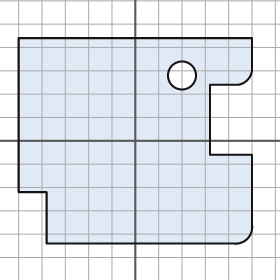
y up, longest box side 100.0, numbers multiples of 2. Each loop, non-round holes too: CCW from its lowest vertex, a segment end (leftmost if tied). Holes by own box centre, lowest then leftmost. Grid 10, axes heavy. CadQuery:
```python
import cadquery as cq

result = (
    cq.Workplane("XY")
    .moveTo(-38.0, -44.0)
    .lineTo(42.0, -44.0)
    .threePointArc((48.0, -42.0), (50.0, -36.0))
    .lineTo(50.0, -6.0)
    .lineTo(32.0, -6.0)
    .lineTo(32.0, 24.0)
    .lineTo(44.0, 24.0)
    .threePointArc((48.0, 26.0), (50.0, 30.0))
    .lineTo(50.0, 44.0)
    .lineTo(-50.0, 44.0)
    .lineTo(-50.0, -22.0)
    .lineTo(-38.0, -22.0)
    .close()
    .moveTo(20.0, 28.0)
    .circle(6.0)
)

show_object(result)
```